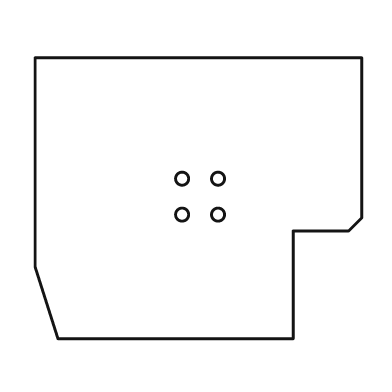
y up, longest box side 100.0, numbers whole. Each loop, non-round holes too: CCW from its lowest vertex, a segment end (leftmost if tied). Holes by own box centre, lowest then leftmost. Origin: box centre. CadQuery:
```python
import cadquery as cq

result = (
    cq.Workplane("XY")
    .moveTo(-43.0, -43.0)
    .lineTo(29.0, -43.0)
    .lineTo(29.0, -10.0)
    .lineTo(46.0, -10.0)
    .lineTo(50.0, -6.0)
    .lineTo(50.0, 43.0)
    .lineTo(-50.0, 43.0)
    .lineTo(-50.0, -21.0)
    .close()
    .moveTo(-5.0, -5.0)
    .circle(2.0)
    .moveTo(6.0, -5.0)
    .circle(2.0)
    .moveTo(-5.0, 6.0)
    .circle(2.0)
    .moveTo(6.0, 6.0)
    .circle(2.0)
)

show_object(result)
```